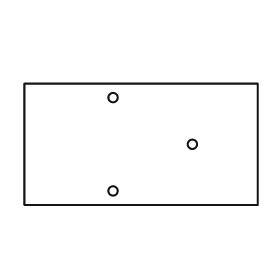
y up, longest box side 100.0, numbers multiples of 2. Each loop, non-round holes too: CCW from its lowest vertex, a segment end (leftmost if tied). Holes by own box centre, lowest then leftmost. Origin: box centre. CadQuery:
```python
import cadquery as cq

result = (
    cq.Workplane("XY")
    .moveTo(-50.0, -26.0)
    .lineTo(50.0, -26.0)
    .lineTo(50.0, 26.0)
    .lineTo(-50.0, 26.0)
    .close()
    .moveTo(-12.0, -20.0)
    .circle(2.0)
    .moveTo(22.0, 0.0)
    .circle(2.0)
    .moveTo(-12.0, 20.0)
    .circle(2.0)
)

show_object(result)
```